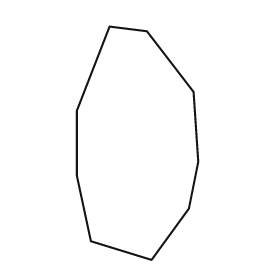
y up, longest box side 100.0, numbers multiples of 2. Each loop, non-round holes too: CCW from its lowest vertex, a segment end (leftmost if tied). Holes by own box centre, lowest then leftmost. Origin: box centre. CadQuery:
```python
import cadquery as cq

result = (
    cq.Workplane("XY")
    .moveTo(6.0, -50.0)
    .lineTo(22.0, -28.0)
    .lineTo(26.0, -8.0)
    .lineTo(24.0, 22.0)
    .lineTo(4.0, 48.0)
    .lineTo(-12.0, 50.0)
    .lineTo(-26.0, 14.0)
    .lineTo(-26.0, -14.0)
    .lineTo(-20.0, -42.0)
    .close()
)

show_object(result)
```